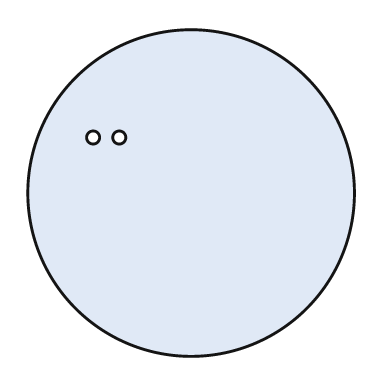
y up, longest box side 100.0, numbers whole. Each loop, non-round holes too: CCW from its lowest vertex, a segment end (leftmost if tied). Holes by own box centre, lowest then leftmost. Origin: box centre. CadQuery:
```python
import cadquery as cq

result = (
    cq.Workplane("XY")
    .moveTo(0.0, 0.0)
    .circle(50.0)
    .moveTo(-30.0, 17.0)
    .circle(2.0)
    .moveTo(-22.0, 17.0)
    .circle(2.0)
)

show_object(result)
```